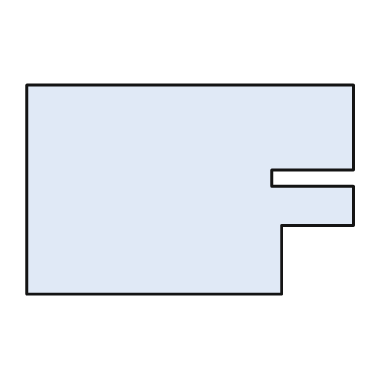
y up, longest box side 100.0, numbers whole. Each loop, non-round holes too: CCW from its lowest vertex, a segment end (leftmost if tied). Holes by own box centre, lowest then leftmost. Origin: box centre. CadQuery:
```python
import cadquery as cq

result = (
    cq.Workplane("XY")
    .moveTo(-50.0, -32.0)
    .lineTo(28.0, -32.0)
    .lineTo(28.0, -11.0)
    .lineTo(50.0, -11.0)
    .lineTo(50.0, 1.0)
    .lineTo(25.0, 1.0)
    .lineTo(25.0, 6.0)
    .lineTo(50.0, 6.0)
    .lineTo(50.0, 32.0)
    .lineTo(-50.0, 32.0)
    .close()
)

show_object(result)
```